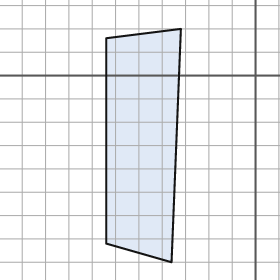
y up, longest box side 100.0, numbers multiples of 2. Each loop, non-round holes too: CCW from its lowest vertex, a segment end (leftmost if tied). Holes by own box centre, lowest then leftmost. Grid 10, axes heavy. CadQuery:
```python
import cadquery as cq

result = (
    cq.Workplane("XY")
    .moveTo(-36.0, -80.0)
    .lineTo(-32.0, 20.0)
    .lineTo(-64.0, 16.0)
    .lineTo(-64.0, -72.0)
    .close()
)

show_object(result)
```